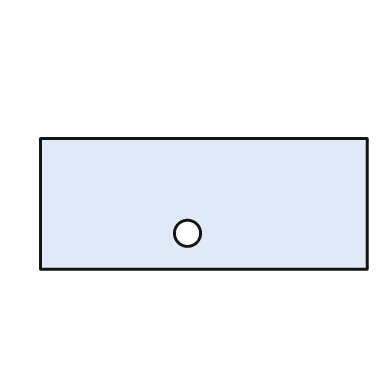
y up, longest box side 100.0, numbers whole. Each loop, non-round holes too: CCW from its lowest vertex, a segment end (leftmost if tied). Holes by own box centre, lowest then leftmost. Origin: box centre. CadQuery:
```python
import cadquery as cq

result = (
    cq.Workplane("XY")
    .moveTo(-50.0, -20.0)
    .lineTo(50.0, -20.0)
    .lineTo(50.0, 20.0)
    .lineTo(-50.0, 20.0)
    .close()
    .moveTo(-5.0, -9.0)
    .circle(4.0)
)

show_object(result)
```